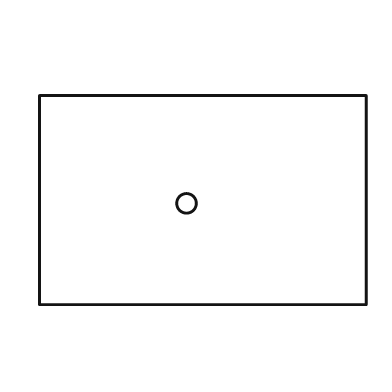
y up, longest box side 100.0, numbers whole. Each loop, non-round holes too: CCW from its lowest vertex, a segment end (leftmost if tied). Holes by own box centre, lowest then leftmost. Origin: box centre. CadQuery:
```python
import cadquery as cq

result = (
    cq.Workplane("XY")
    .moveTo(-50.0, -32.0)
    .lineTo(50.0, -32.0)
    .lineTo(50.0, 32.0)
    .lineTo(-50.0, 32.0)
    .close()
    .moveTo(-5.0, -1.0)
    .circle(3.0)
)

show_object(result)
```